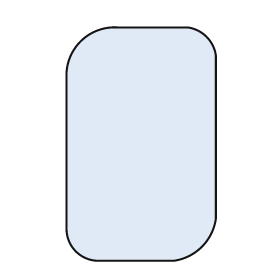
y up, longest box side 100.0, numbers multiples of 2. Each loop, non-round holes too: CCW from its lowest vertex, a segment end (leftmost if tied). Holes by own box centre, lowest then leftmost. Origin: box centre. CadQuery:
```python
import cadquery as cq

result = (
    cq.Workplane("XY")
    .moveTo(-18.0, -50.0)
    .lineTo(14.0, -50.0)
    .threePointArc((26.0, -44.0), (32.0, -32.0))
    .lineTo(32.0, 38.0)
    .threePointArc((28.0, 46.0), (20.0, 50.0))
    .lineTo(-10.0, 50.0)
    .threePointArc((-26.0, 44.0), (-32.0, 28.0))
    .lineTo(-32.0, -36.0)
    .threePointArc((-28.0, -46.0), (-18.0, -50.0))
    .close()
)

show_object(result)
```